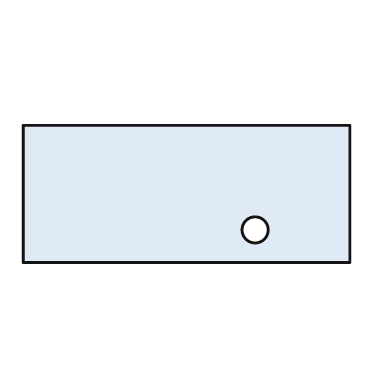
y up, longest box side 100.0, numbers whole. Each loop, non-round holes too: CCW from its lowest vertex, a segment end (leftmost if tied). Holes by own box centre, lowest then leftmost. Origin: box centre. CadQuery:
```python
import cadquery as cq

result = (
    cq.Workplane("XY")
    .moveTo(-50.0, -21.0)
    .lineTo(50.0, -21.0)
    .lineTo(50.0, 21.0)
    .lineTo(-50.0, 21.0)
    .close()
    .moveTo(21.0, -11.0)
    .circle(4.0)
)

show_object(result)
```